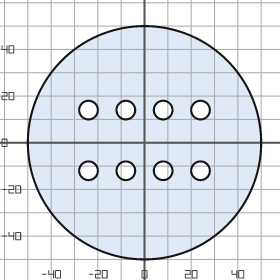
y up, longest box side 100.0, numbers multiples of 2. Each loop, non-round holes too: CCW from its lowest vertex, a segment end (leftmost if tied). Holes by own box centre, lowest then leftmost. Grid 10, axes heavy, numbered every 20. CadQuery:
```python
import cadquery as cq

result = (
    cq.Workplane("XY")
    .moveTo(0.0, 0.0)
    .circle(50.0)
    .moveTo(-24.0, -12.0)
    .circle(4.0)
    .moveTo(-8.0, -12.0)
    .circle(4.0)
    .moveTo(8.0, -12.0)
    .circle(4.0)
    .moveTo(24.0, -12.0)
    .circle(4.0)
    .moveTo(-24.0, 14.0)
    .circle(4.0)
    .moveTo(-8.0, 14.0)
    .circle(4.0)
    .moveTo(8.0, 14.0)
    .circle(4.0)
    .moveTo(24.0, 14.0)
    .circle(4.0)
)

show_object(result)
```